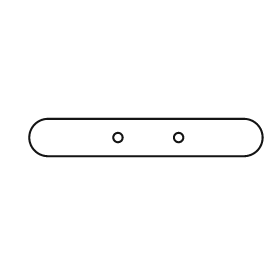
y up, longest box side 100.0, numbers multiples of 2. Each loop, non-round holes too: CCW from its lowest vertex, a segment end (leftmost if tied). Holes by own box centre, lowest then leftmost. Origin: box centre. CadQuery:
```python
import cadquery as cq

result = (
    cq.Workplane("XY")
    .moveTo(-42.0, -8.0)
    .lineTo(42.0, -8.0)
    .threePointArc((50.0, 0.0), (42.0, 8.0))
    .lineTo(-42.0, 8.0)
    .threePointArc((-50.0, 0.0), (-42.0, -8.0))
    .close()
    .moveTo(-12.0, 0.0)
    .circle(2.0)
    .moveTo(14.0, 0.0)
    .circle(2.0)
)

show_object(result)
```